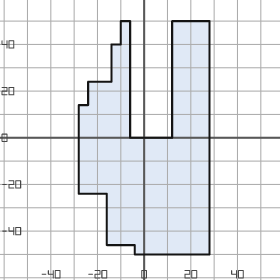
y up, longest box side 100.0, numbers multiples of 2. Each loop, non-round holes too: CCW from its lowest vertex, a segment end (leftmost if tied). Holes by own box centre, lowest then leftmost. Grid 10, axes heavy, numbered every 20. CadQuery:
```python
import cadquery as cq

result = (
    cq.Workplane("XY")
    .moveTo(-4.0, -50.0)
    .lineTo(28.0, -50.0)
    .lineTo(28.0, 50.0)
    .lineTo(12.0, 50.0)
    .lineTo(12.0, 0.0)
    .lineTo(-6.0, 0.0)
    .lineTo(-6.0, 50.0)
    .lineTo(-10.0, 50.0)
    .lineTo(-10.0, 40.0)
    .lineTo(-14.0, 40.0)
    .lineTo(-14.0, 24.0)
    .lineTo(-24.0, 24.0)
    .lineTo(-24.0, 14.0)
    .lineTo(-28.0, 14.0)
    .lineTo(-28.0, -24.0)
    .lineTo(-16.0, -24.0)
    .lineTo(-16.0, -46.0)
    .lineTo(-4.0, -46.0)
    .close()
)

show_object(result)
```